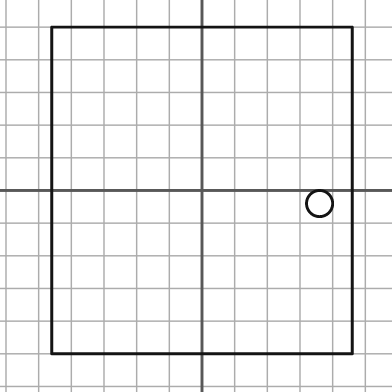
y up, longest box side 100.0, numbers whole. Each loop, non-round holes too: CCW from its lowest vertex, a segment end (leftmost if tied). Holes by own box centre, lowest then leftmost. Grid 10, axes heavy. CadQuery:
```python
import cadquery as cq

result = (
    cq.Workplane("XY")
    .moveTo(-46.0, -50.0)
    .lineTo(46.0, -50.0)
    .lineTo(46.0, 50.0)
    .lineTo(-46.0, 50.0)
    .close()
    .moveTo(36.0, -4.0)
    .circle(4.0)
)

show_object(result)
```